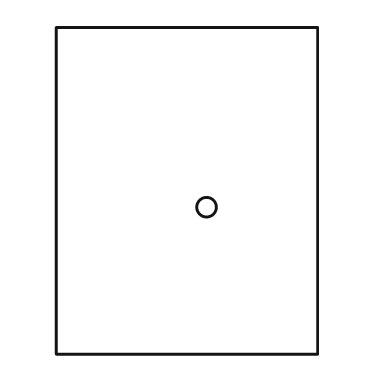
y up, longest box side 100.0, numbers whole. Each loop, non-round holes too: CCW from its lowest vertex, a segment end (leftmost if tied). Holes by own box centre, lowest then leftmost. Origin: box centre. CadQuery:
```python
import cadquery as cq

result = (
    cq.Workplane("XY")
    .moveTo(-40.0, -50.0)
    .lineTo(40.0, -50.0)
    .lineTo(40.0, 50.0)
    .lineTo(-40.0, 50.0)
    .close()
    .moveTo(6.0, -5.0)
    .circle(3.0)
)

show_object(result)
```